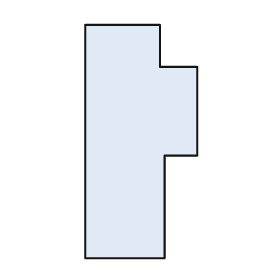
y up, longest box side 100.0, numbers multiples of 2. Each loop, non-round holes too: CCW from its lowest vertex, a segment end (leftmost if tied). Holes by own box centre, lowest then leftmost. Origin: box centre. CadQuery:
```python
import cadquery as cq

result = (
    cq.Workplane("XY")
    .moveTo(-24.0, -50.0)
    .lineTo(10.0, -50.0)
    .lineTo(10.0, -6.0)
    .lineTo(24.0, -6.0)
    .lineTo(24.0, 32.0)
    .lineTo(8.0, 32.0)
    .lineTo(8.0, 50.0)
    .lineTo(-24.0, 50.0)
    .close()
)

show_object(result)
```